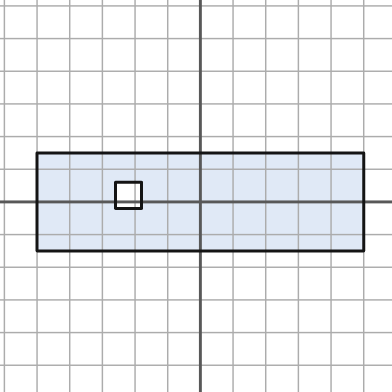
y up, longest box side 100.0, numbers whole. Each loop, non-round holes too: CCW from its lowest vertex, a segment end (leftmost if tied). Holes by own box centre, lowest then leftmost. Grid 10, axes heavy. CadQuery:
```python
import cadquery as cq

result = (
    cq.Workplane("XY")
    .moveTo(-50.0, -15.0)
    .lineTo(50.0, -15.0)
    .lineTo(50.0, 15.0)
    .lineTo(-50.0, 15.0)
    .close()
    .moveTo(-26.0, -2.0)
    .lineTo(-18.0, -2.0)
    .lineTo(-18.0, 6.0)
    .lineTo(-26.0, 6.0)
    .close()
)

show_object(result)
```